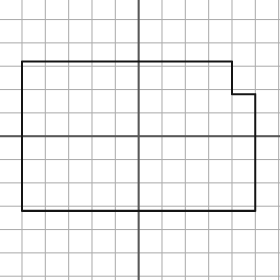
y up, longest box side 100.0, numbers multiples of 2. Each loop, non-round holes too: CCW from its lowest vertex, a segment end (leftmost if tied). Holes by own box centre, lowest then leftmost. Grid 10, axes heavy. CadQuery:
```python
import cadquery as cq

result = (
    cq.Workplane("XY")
    .moveTo(-50.0, -32.0)
    .lineTo(50.0, -32.0)
    .lineTo(50.0, 18.0)
    .lineTo(40.0, 18.0)
    .lineTo(40.0, 32.0)
    .lineTo(-50.0, 32.0)
    .close()
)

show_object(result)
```